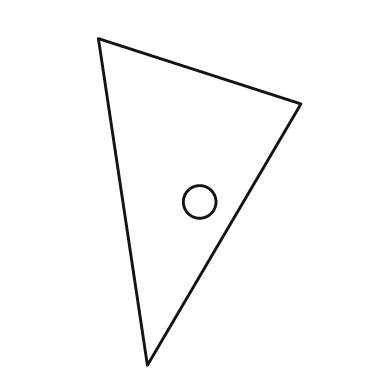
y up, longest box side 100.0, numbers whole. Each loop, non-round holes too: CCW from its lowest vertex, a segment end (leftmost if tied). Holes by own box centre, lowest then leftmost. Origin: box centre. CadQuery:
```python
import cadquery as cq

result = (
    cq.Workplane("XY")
    .moveTo(-16.0, -50.0)
    .lineTo(31.0, 30.0)
    .lineTo(-31.0, 50.0)
    .close()
    .moveTo(0.0, 0.0)
    .circle(5.0)
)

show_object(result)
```